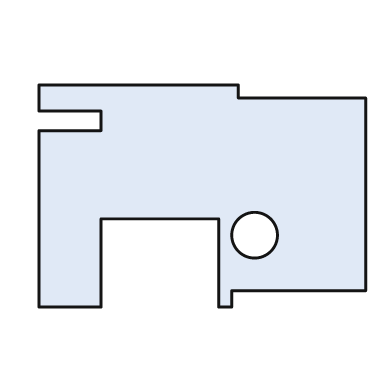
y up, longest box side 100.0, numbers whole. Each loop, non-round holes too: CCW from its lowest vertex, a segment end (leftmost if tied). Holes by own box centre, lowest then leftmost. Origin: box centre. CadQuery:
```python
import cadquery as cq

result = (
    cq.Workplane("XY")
    .moveTo(-50.0, -34.0)
    .lineTo(-31.0, -34.0)
    .lineTo(-31.0, -7.0)
    .lineTo(5.0, -7.0)
    .lineTo(5.0, -34.0)
    .lineTo(9.0, -34.0)
    .lineTo(9.0, -29.0)
    .lineTo(50.0, -29.0)
    .lineTo(50.0, 30.0)
    .lineTo(11.0, 30.0)
    .lineTo(11.0, 34.0)
    .lineTo(-50.0, 34.0)
    .lineTo(-50.0, 26.0)
    .lineTo(-31.0, 26.0)
    .lineTo(-31.0, 20.0)
    .lineTo(-50.0, 20.0)
    .close()
    .moveTo(16.0, -12.0)
    .circle(7.0)
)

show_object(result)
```